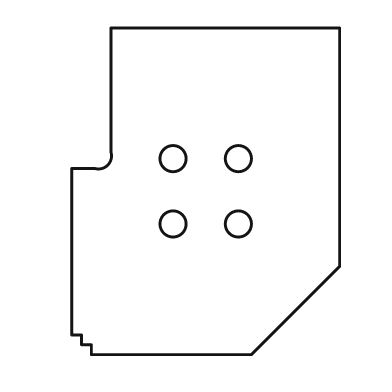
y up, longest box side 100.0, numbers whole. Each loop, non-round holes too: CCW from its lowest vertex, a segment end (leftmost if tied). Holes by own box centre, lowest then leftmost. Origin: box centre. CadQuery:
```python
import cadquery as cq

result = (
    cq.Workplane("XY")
    .moveTo(-35.0, -50.0)
    .lineTo(14.0, -50.0)
    .lineTo(41.0, -23.0)
    .lineTo(41.0, 50.0)
    .lineTo(-29.0, 50.0)
    .lineTo(-29.0, 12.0)
    .threePointArc((-30.0, 8.0), (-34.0, 7.0))
    .lineTo(-41.0, 7.0)
    .lineTo(-41.0, -44.0)
    .lineTo(-38.0, -44.0)
    .lineTo(-38.0, -47.0)
    .lineTo(-35.0, -47.0)
    .close()
    .moveTo(-10.0, -10.0)
    .circle(4.0)
    .moveTo(10.0, -10.0)
    .circle(4.0)
    .moveTo(-10.0, 10.0)
    .circle(4.0)
    .moveTo(10.0, 10.0)
    .circle(4.0)
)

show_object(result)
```